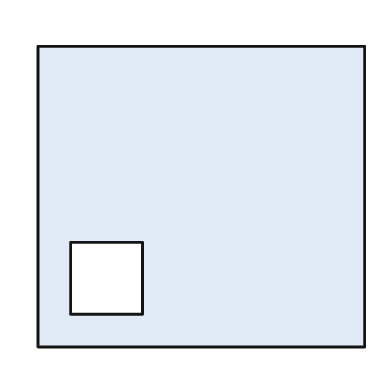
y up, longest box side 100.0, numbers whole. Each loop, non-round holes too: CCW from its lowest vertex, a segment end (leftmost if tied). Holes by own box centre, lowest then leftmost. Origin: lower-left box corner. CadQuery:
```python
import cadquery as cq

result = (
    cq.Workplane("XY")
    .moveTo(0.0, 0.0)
    .lineTo(100.0, 0.0)
    .lineTo(100.0, 92.0)
    .lineTo(0.0, 92.0)
    .close()
    .moveTo(10.0, 10.0)
    .lineTo(32.0, 10.0)
    .lineTo(32.0, 32.0)
    .lineTo(10.0, 32.0)
    .close()
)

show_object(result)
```